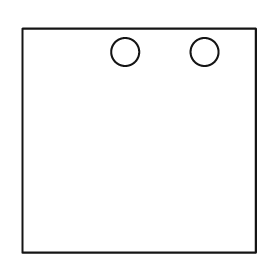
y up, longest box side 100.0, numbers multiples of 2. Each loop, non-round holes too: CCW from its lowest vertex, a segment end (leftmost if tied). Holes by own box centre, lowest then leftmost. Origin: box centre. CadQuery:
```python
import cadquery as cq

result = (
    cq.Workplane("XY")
    .moveTo(-50.0, -48.0)
    .lineTo(50.0, -48.0)
    .lineTo(50.0, 48.0)
    .lineTo(-50.0, 48.0)
    .close()
    .moveTo(-6.0, 38.0)
    .circle(6.0)
    .moveTo(28.0, 38.0)
    .circle(6.0)
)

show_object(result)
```